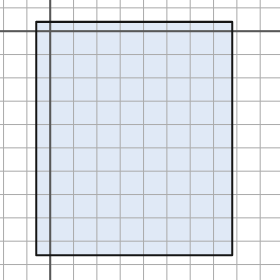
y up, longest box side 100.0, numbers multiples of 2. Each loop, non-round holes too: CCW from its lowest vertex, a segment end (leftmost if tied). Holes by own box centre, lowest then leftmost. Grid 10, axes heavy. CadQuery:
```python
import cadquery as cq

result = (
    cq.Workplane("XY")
    .moveTo(-6.0, -96.0)
    .lineTo(78.0, -96.0)
    .lineTo(78.0, 4.0)
    .lineTo(-6.0, 4.0)
    .close()
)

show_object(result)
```